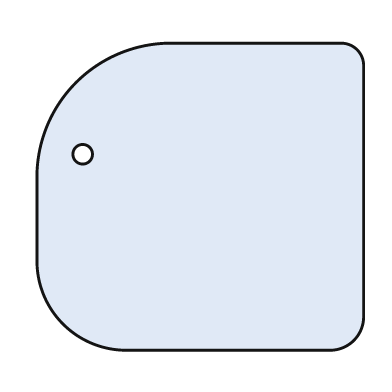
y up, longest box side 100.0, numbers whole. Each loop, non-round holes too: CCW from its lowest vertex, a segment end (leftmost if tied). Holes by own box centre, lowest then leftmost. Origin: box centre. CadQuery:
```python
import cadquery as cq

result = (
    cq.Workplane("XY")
    .moveTo(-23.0, -47.0)
    .lineTo(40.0, -47.0)
    .threePointArc((47.0, -44.0), (50.0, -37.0))
    .lineTo(50.0, 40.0)
    .threePointArc((48.0, 45.0), (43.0, 47.0))
    .lineTo(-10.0, 47.0)
    .threePointArc((-38.0, 35.0), (-50.0, 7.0))
    .lineTo(-50.0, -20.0)
    .threePointArc((-42.0, -39.0), (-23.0, -47.0))
    .close()
    .moveTo(-36.0, 13.0)
    .circle(3.0)
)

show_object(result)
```